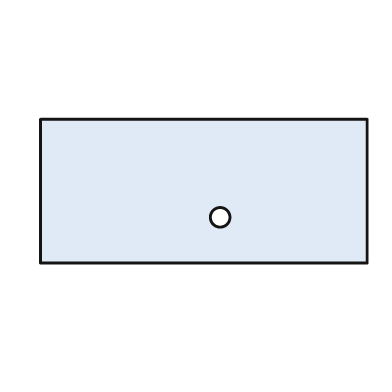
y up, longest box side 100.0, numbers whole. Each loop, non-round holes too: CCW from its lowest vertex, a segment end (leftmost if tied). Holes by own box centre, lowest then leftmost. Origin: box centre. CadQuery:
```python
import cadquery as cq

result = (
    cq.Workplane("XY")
    .moveTo(-50.0, -22.0)
    .lineTo(50.0, -22.0)
    .lineTo(50.0, 22.0)
    .lineTo(-50.0, 22.0)
    .close()
    .moveTo(5.0, -8.0)
    .circle(3.0)
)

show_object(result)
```